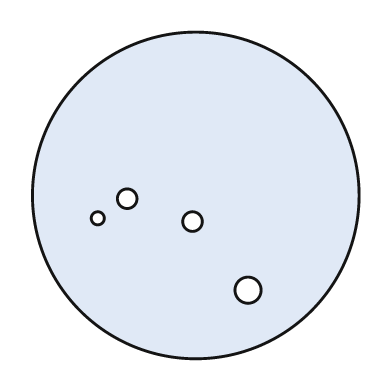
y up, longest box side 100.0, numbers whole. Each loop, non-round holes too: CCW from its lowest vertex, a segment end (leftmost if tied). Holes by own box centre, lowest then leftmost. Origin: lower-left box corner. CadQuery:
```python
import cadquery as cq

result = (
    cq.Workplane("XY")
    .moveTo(50.0, 50.0)
    .circle(50.0)
    .moveTo(66.0, 21.0)
    .circle(4.0)
    .moveTo(49.0, 42.0)
    .circle(3.0)
    .moveTo(20.0, 43.0)
    .circle(2.0)
    .moveTo(29.0, 49.0)
    .circle(3.0)
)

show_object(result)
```